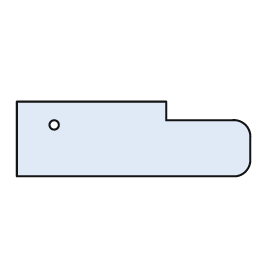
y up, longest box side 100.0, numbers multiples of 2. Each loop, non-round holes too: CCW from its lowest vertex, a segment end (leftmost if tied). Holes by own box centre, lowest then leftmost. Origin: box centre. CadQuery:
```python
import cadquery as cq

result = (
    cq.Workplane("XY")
    .moveTo(-50.0, -16.0)
    .lineTo(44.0, -16.0)
    .threePointArc((48.0, -14.0), (50.0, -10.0))
    .lineTo(50.0, 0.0)
    .threePointArc((48.0, 6.0), (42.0, 8.0))
    .lineTo(14.0, 8.0)
    .lineTo(14.0, 16.0)
    .lineTo(-50.0, 16.0)
    .close()
    .moveTo(-34.0, 6.0)
    .circle(2.0)
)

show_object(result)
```